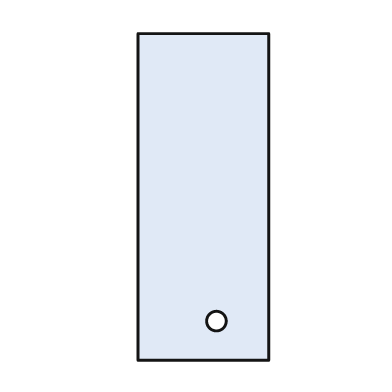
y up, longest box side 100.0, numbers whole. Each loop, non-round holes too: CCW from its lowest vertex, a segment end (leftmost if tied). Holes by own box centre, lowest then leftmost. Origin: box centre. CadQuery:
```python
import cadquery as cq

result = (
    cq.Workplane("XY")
    .moveTo(-20.0, -50.0)
    .lineTo(20.0, -50.0)
    .lineTo(20.0, 50.0)
    .lineTo(-20.0, 50.0)
    .close()
    .moveTo(4.0, -38.0)
    .circle(3.0)
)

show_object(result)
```